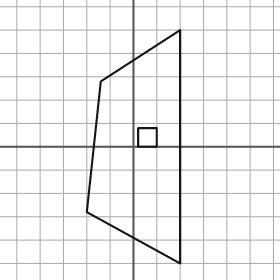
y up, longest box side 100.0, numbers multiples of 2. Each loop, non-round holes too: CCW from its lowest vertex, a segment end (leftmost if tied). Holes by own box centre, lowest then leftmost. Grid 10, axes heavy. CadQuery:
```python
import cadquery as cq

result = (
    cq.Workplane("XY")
    .moveTo(20.0, -50.0)
    .lineTo(20.0, 50.0)
    .lineTo(-14.0, 28.0)
    .lineTo(-20.0, -28.0)
    .close()
    .moveTo(2.0, 0.0)
    .lineTo(10.0, 0.0)
    .lineTo(10.0, 8.0)
    .lineTo(2.0, 8.0)
    .close()
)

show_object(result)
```